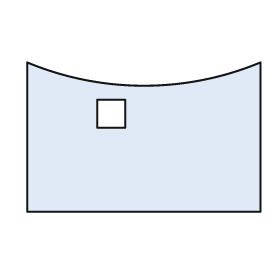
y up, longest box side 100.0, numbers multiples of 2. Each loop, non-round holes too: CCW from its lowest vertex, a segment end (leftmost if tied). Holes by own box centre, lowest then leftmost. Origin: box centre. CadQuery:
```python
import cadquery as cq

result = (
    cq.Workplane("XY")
    .moveTo(-50.0, -32.0)
    .lineTo(50.0, -32.0)
    .lineTo(50.0, 32.0)
    .threePointArc((0.0, 22.0), (-50.0, 32.0))
    .close()
    .moveTo(-20.0, 4.0)
    .lineTo(-8.0, 4.0)
    .lineTo(-8.0, 16.0)
    .lineTo(-20.0, 16.0)
    .close()
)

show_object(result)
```